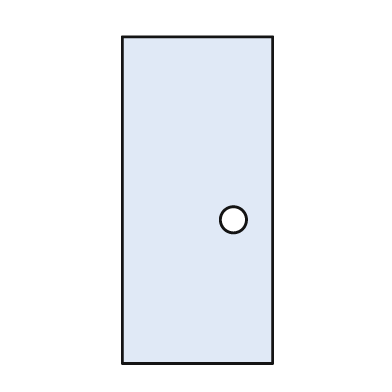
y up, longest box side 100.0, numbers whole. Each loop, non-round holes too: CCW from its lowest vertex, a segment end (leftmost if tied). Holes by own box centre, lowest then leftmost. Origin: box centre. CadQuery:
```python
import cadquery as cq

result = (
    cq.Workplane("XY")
    .moveTo(-23.0, -50.0)
    .lineTo(23.0, -50.0)
    .lineTo(23.0, 50.0)
    .lineTo(-23.0, 50.0)
    .close()
    .moveTo(11.0, -6.0)
    .circle(4.0)
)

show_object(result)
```